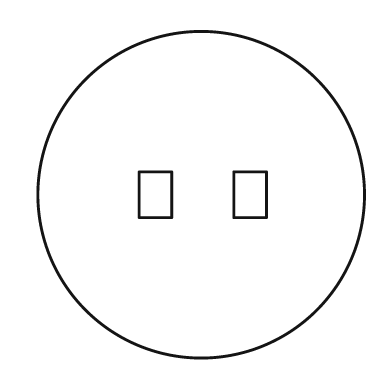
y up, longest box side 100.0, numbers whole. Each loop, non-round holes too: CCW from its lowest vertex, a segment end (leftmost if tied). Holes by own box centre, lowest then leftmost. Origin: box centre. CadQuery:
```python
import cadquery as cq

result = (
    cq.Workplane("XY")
    .moveTo(0.0, 0.0)
    .circle(50.0)
    .moveTo(-19.0, -7.0)
    .lineTo(-9.0, -7.0)
    .lineTo(-9.0, 7.0)
    .lineTo(-19.0, 7.0)
    .close()
    .moveTo(10.0, -7.0)
    .lineTo(20.0, -7.0)
    .lineTo(20.0, 7.0)
    .lineTo(10.0, 7.0)
    .close()
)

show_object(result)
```